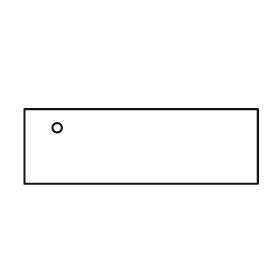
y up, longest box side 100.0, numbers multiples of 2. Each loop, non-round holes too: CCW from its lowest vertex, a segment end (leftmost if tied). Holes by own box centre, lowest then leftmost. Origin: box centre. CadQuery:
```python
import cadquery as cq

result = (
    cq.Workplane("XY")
    .moveTo(-50.0, -16.0)
    .lineTo(50.0, -16.0)
    .lineTo(50.0, 16.0)
    .lineTo(-50.0, 16.0)
    .close()
    .moveTo(-36.0, 8.0)
    .circle(2.0)
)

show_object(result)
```